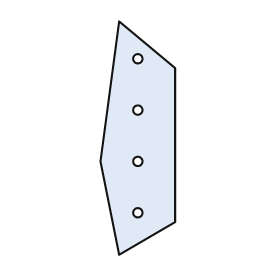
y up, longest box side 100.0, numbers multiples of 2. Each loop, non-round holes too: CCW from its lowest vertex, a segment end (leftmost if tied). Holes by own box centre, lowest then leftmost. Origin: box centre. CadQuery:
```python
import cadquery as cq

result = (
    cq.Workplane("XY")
    .moveTo(-8.0, -50.0)
    .lineTo(16.0, -36.0)
    .lineTo(16.0, 30.0)
    .lineTo(-8.0, 50.0)
    .lineTo(-16.0, -10.0)
    .close()
    .moveTo(0.0, -32.0)
    .circle(2.0)
    .moveTo(0.0, -10.0)
    .circle(2.0)
    .moveTo(0.0, 12.0)
    .circle(2.0)
    .moveTo(0.0, 34.0)
    .circle(2.0)
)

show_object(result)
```